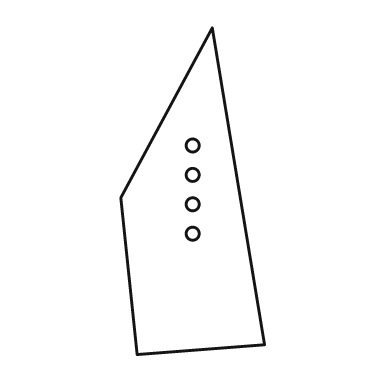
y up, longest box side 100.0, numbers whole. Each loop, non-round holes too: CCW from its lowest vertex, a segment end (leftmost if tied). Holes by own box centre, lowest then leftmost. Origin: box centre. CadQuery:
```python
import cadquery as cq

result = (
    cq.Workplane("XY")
    .moveTo(-17.0, -50.0)
    .lineTo(22.0, -47.0)
    .lineTo(6.0, 50.0)
    .lineTo(-22.0, -2.0)
    .close()
    .moveTo(0.0, -13.0)
    .circle(2.0)
    .moveTo(0.0, -4.0)
    .circle(2.0)
    .moveTo(0.0, 5.0)
    .circle(2.0)
    .moveTo(0.0, 14.0)
    .circle(2.0)
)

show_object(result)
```